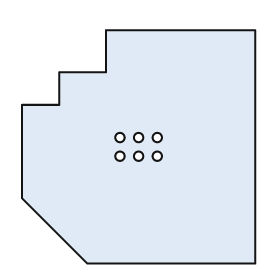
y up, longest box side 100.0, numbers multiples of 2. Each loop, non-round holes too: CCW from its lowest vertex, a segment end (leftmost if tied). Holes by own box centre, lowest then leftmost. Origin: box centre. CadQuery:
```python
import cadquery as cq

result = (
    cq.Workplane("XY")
    .moveTo(-22.0, -50.0)
    .lineTo(50.0, -50.0)
    .lineTo(50.0, 50.0)
    .lineTo(-14.0, 50.0)
    .lineTo(-14.0, 32.0)
    .lineTo(-34.0, 32.0)
    .lineTo(-34.0, 18.0)
    .lineTo(-50.0, 18.0)
    .lineTo(-50.0, -22.0)
    .close()
    .moveTo(-8.0, -4.0)
    .circle(2.0)
    .moveTo(0.0, -4.0)
    .circle(2.0)
    .moveTo(8.0, -4.0)
    .circle(2.0)
    .moveTo(-8.0, 4.0)
    .circle(2.0)
    .moveTo(0.0, 4.0)
    .circle(2.0)
    .moveTo(8.0, 4.0)
    .circle(2.0)
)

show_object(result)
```